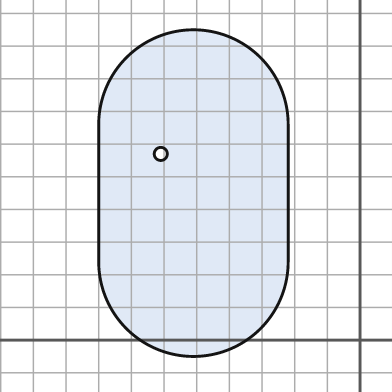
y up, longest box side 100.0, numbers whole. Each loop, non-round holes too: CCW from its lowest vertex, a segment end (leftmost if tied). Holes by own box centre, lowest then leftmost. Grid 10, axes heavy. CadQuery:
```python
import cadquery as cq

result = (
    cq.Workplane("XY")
    .moveTo(-80.0, 24.0)
    .threePointArc((-51.0, -5.0), (-22.0, 24.0))
    .lineTo(-22.0, 66.0)
    .threePointArc((-51.0, 95.0), (-80.0, 66.0))
    .close()
    .moveTo(-61.0, 57.0)
    .circle(2.0)
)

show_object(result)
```